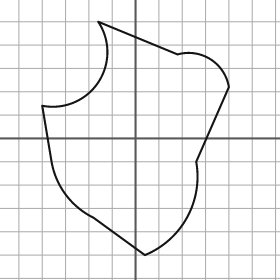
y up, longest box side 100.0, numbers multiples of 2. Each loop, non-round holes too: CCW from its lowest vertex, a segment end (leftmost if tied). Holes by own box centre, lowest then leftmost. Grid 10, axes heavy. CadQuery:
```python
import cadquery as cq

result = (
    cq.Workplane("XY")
    .moveTo(4.0, -50.0)
    .threePointArc((22.0, -34.0), (26.0, -10.0))
    .lineTo(40.0, 22.0)
    .threePointArc((32.0, 34.0), (18.0, 36.0))
    .lineTo(-16.0, 50.0)
    .threePointArc((-16.0, 24.0), (-40.0, 14.0))
    .lineTo(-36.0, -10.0)
    .threePointArc((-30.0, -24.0), (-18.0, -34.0))
    .close()
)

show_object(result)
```